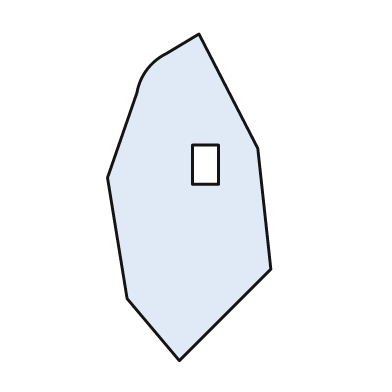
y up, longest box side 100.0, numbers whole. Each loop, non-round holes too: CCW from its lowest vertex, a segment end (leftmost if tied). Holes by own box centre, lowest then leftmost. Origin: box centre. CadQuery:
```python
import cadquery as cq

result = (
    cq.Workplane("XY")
    .moveTo(-3.0, -50.0)
    .lineTo(25.0, -22.0)
    .lineTo(21.0, 15.0)
    .lineTo(3.0, 50.0)
    .lineTo(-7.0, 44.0)
    .threePointArc((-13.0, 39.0), (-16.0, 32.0))
    .lineTo(-25.0, 6.0)
    .lineTo(-19.0, -31.0)
    .close()
    .moveTo(1.0, 4.0)
    .lineTo(9.0, 4.0)
    .lineTo(9.0, 16.0)
    .lineTo(1.0, 16.0)
    .close()
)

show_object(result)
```